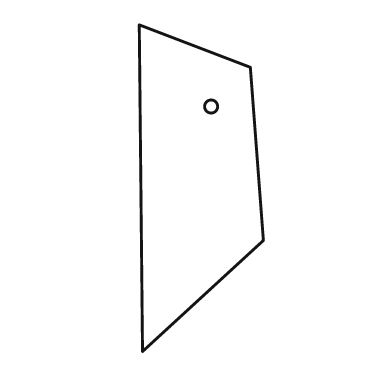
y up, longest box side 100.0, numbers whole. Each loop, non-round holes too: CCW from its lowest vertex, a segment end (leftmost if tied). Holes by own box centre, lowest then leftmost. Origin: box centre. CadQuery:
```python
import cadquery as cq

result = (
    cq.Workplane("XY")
    .moveTo(-18.0, -50.0)
    .lineTo(19.0, -16.0)
    .lineTo(15.0, 37.0)
    .lineTo(-19.0, 50.0)
    .close()
    .moveTo(3.0, 25.0)
    .circle(2.0)
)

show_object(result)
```